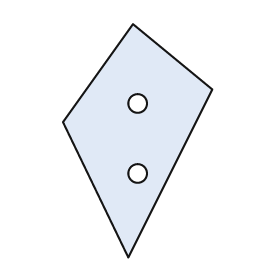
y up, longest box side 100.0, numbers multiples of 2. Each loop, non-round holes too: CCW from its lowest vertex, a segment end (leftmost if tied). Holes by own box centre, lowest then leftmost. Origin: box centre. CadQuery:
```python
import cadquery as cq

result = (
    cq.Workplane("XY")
    .moveTo(-4.0, -50.0)
    .lineTo(32.0, 22.0)
    .lineTo(-2.0, 50.0)
    .lineTo(-32.0, 8.0)
    .close()
    .moveTo(0.0, -14.0)
    .circle(4.0)
    .moveTo(0.0, 16.0)
    .circle(4.0)
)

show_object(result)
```